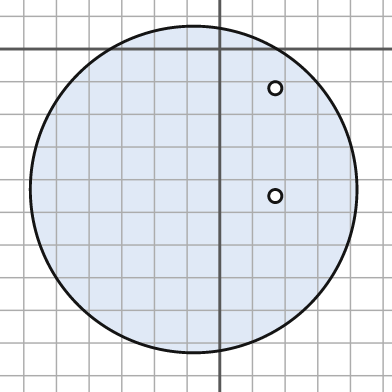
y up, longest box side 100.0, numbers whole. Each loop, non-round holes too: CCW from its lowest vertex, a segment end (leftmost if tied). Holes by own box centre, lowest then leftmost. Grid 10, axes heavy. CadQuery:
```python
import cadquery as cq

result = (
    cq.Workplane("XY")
    .moveTo(-8.0, -43.0)
    .circle(50.0)
    .moveTo(17.0, -45.0)
    .circle(2.0)
    .moveTo(17.0, -12.0)
    .circle(2.0)
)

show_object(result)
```